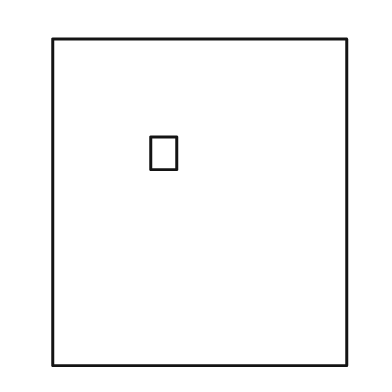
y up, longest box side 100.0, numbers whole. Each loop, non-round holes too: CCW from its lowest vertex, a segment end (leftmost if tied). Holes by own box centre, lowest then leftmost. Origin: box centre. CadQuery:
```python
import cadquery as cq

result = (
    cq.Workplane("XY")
    .moveTo(-45.0, -50.0)
    .lineTo(45.0, -50.0)
    .lineTo(45.0, 50.0)
    .lineTo(-45.0, 50.0)
    .close()
    .moveTo(-15.0, 10.0)
    .lineTo(-7.0, 10.0)
    .lineTo(-7.0, 20.0)
    .lineTo(-15.0, 20.0)
    .close()
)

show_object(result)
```